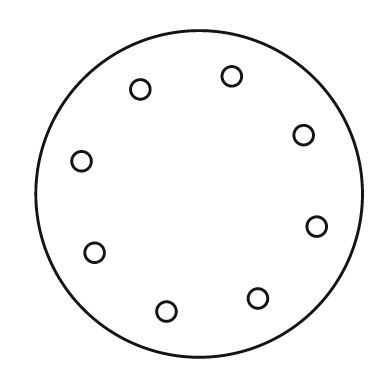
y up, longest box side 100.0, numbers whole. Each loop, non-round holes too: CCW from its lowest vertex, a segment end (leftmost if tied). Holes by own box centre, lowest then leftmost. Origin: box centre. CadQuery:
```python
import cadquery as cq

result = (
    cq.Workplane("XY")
    .moveTo(0.0, 0.0)
    .circle(50.0)
    .moveTo(-10.0, -36.0)
    .circle(3.0)
    .moveTo(18.0, -32.0)
    .circle(3.0)
    .moveTo(-32.0, -18.0)
    .circle(3.0)
    .moveTo(36.0, -10.0)
    .circle(3.0)
    .moveTo(-36.0, 10.0)
    .circle(3.0)
    .moveTo(32.0, 18.0)
    .circle(3.0)
    .moveTo(-18.0, 32.0)
    .circle(3.0)
    .moveTo(10.0, 36.0)
    .circle(3.0)
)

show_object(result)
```